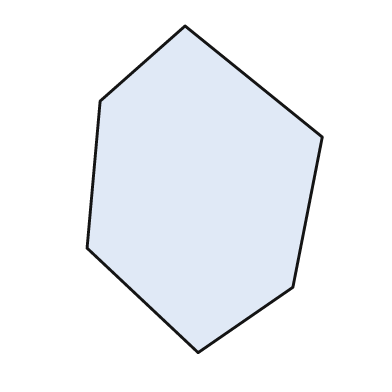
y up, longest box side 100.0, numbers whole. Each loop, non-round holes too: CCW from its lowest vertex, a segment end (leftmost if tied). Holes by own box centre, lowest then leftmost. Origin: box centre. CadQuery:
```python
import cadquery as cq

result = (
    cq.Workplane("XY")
    .moveTo(-2.0, -50.0)
    .lineTo(27.0, -30.0)
    .lineTo(36.0, 16.0)
    .lineTo(-6.0, 50.0)
    .lineTo(-32.0, 27.0)
    .lineTo(-36.0, -18.0)
    .close()
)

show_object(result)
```